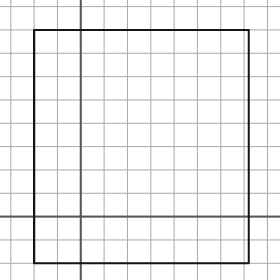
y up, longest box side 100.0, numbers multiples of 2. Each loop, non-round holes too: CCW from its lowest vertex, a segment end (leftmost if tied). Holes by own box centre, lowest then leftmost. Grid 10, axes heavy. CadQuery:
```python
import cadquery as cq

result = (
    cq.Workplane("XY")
    .moveTo(-20.0, -20.0)
    .lineTo(72.0, -20.0)
    .lineTo(72.0, 80.0)
    .lineTo(-20.0, 80.0)
    .close()
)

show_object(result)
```